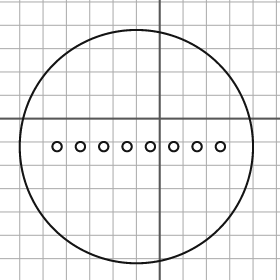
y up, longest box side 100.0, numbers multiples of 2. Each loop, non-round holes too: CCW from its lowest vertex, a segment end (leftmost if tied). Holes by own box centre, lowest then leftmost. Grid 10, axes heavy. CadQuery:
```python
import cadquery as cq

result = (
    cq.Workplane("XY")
    .moveTo(-10.0, -12.0)
    .circle(50.0)
    .moveTo(-44.0, -12.0)
    .circle(2.0)
    .moveTo(-34.0, -12.0)
    .circle(2.0)
    .moveTo(-24.0, -12.0)
    .circle(2.0)
    .moveTo(-14.0, -12.0)
    .circle(2.0)
    .moveTo(-4.0, -12.0)
    .circle(2.0)
    .moveTo(6.0, -12.0)
    .circle(2.0)
    .moveTo(16.0, -12.0)
    .circle(2.0)
    .moveTo(26.0, -12.0)
    .circle(2.0)
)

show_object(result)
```